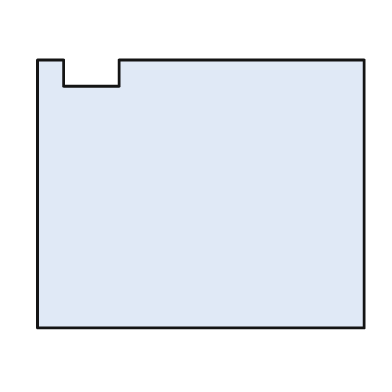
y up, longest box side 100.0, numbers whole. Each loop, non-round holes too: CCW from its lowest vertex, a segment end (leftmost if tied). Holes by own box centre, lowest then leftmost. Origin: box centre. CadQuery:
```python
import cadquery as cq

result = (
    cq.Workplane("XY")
    .moveTo(-50.0, -41.0)
    .lineTo(50.0, -41.0)
    .lineTo(50.0, 41.0)
    .lineTo(-25.0, 41.0)
    .lineTo(-25.0, 33.0)
    .lineTo(-42.0, 33.0)
    .lineTo(-42.0, 41.0)
    .lineTo(-50.0, 41.0)
    .close()
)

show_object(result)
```